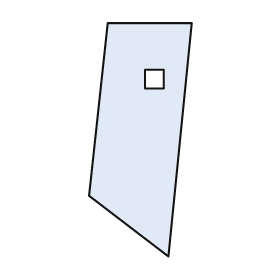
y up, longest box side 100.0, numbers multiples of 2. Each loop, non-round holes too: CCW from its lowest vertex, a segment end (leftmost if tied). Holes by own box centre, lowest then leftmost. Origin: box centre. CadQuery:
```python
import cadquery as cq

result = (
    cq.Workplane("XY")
    .moveTo(12.0, -50.0)
    .lineTo(22.0, 50.0)
    .lineTo(-14.0, 50.0)
    .lineTo(-22.0, -24.0)
    .close()
    .moveTo(2.0, 22.0)
    .lineTo(10.0, 22.0)
    .lineTo(10.0, 30.0)
    .lineTo(2.0, 30.0)
    .close()
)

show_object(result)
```